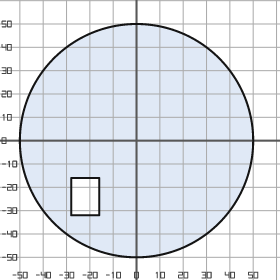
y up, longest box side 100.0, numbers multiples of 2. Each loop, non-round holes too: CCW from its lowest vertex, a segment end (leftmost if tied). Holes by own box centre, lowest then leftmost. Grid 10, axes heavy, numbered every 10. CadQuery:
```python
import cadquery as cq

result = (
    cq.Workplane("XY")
    .moveTo(0.0, 0.0)
    .circle(50.0)
    .moveTo(-28.0, -32.0)
    .lineTo(-16.0, -32.0)
    .lineTo(-16.0, -16.0)
    .lineTo(-28.0, -16.0)
    .close()
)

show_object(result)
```